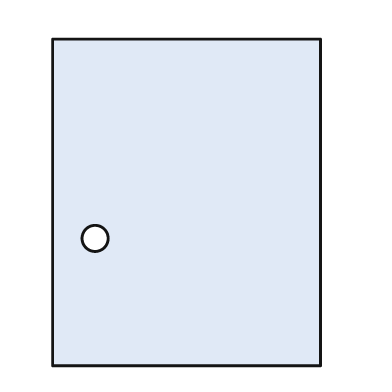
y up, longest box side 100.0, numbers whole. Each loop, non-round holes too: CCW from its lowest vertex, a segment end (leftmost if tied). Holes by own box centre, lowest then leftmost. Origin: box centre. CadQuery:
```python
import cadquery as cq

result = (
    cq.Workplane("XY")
    .moveTo(-41.0, -50.0)
    .lineTo(41.0, -50.0)
    .lineTo(41.0, 50.0)
    .lineTo(-41.0, 50.0)
    .close()
    .moveTo(-28.0, -11.0)
    .circle(4.0)
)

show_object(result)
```